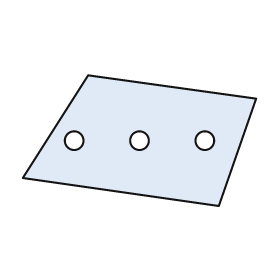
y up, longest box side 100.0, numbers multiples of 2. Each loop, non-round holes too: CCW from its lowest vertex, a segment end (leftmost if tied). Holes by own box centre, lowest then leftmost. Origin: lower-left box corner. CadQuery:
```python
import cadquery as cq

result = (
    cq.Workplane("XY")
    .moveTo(84.0, 0.0)
    .lineTo(100.0, 46.0)
    .lineTo(28.0, 56.0)
    .lineTo(0.0, 12.0)
    .close()
    .moveTo(22.0, 28.0)
    .circle(4.0)
    .moveTo(50.0, 28.0)
    .circle(4.0)
    .moveTo(78.0, 28.0)
    .circle(4.0)
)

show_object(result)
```